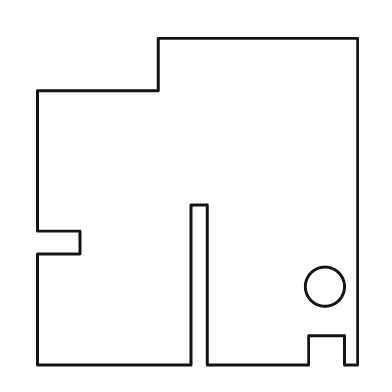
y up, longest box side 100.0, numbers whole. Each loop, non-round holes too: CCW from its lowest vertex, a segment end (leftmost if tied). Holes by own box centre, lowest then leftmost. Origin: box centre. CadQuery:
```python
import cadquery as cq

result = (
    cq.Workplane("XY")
    .moveTo(-49.0, -50.0)
    .lineTo(-2.0, -50.0)
    .lineTo(-2.0, -1.0)
    .lineTo(3.0, -1.0)
    .lineTo(3.0, -50.0)
    .lineTo(34.0, -50.0)
    .lineTo(34.0, -41.0)
    .lineTo(45.0, -41.0)
    .lineTo(45.0, -50.0)
    .lineTo(49.0, -50.0)
    .lineTo(49.0, 50.0)
    .lineTo(-12.0, 50.0)
    .lineTo(-12.0, 34.0)
    .lineTo(-49.0, 34.0)
    .lineTo(-49.0, -9.0)
    .lineTo(-36.0, -9.0)
    .lineTo(-36.0, -16.0)
    .lineTo(-49.0, -16.0)
    .close()
    .moveTo(39.0, -26.0)
    .circle(6.0)
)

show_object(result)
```